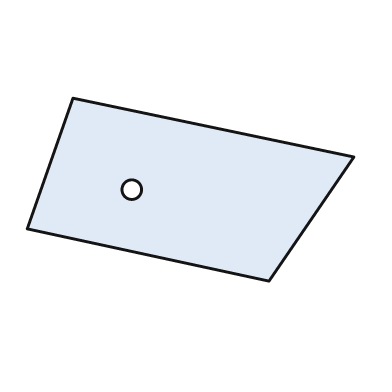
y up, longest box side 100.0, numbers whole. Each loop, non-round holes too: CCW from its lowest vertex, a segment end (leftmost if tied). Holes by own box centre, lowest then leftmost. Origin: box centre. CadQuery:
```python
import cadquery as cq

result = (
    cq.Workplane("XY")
    .moveTo(24.0, -28.0)
    .lineTo(50.0, 10.0)
    .lineTo(-36.0, 28.0)
    .lineTo(-50.0, -12.0)
    .close()
    .moveTo(-18.0, 0.0)
    .circle(3.0)
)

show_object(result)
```